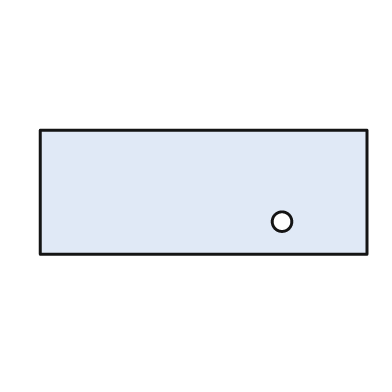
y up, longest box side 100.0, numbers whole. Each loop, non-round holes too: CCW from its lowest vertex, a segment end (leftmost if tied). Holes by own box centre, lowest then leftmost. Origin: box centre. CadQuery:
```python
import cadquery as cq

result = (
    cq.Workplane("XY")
    .moveTo(-50.0, -19.0)
    .lineTo(50.0, -19.0)
    .lineTo(50.0, 19.0)
    .lineTo(-50.0, 19.0)
    .close()
    .moveTo(24.0, -9.0)
    .circle(3.0)
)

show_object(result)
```